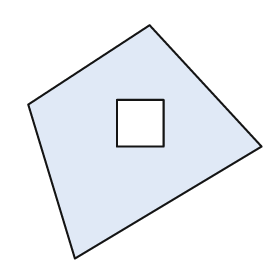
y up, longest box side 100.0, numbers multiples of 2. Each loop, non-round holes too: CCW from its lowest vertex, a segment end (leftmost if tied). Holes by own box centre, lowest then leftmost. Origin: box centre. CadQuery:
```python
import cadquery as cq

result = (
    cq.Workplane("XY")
    .moveTo(-30.0, -50.0)
    .lineTo(50.0, -2.0)
    .lineTo(2.0, 50.0)
    .lineTo(-50.0, 16.0)
    .close()
    .moveTo(-12.0, -2.0)
    .lineTo(8.0, -2.0)
    .lineTo(8.0, 18.0)
    .lineTo(-12.0, 18.0)
    .close()
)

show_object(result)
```